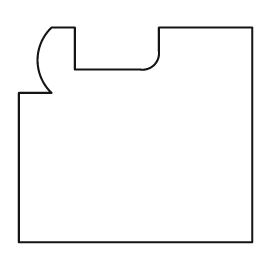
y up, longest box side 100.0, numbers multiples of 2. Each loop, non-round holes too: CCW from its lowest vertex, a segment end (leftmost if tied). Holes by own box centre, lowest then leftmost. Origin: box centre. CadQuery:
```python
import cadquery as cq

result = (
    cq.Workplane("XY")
    .moveTo(-50.0, -46.0)
    .lineTo(50.0, -46.0)
    .lineTo(50.0, 46.0)
    .lineTo(10.0, 46.0)
    .lineTo(10.0, 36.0)
    .threePointArc((8.0, 30.0), (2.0, 28.0))
    .lineTo(-26.0, 28.0)
    .lineTo(-26.0, 46.0)
    .lineTo(-36.0, 46.0)
    .threePointArc((-42.0, 32.0), (-36.0, 18.0))
    .lineTo(-50.0, 18.0)
    .close()
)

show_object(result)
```